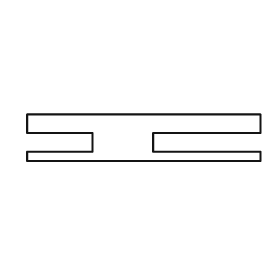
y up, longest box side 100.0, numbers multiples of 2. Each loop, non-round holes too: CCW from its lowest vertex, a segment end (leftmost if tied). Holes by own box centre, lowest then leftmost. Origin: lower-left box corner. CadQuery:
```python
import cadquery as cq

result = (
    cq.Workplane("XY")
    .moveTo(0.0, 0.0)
    .lineTo(100.0, 0.0)
    .lineTo(100.0, 4.0)
    .lineTo(54.0, 4.0)
    .lineTo(54.0, 12.0)
    .lineTo(100.0, 12.0)
    .lineTo(100.0, 20.0)
    .lineTo(0.0, 20.0)
    .lineTo(0.0, 12.0)
    .lineTo(28.0, 12.0)
    .lineTo(28.0, 4.0)
    .lineTo(0.0, 4.0)
    .close()
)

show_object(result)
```